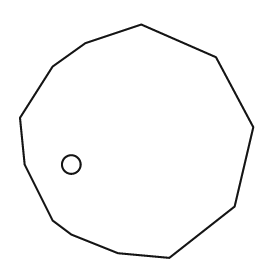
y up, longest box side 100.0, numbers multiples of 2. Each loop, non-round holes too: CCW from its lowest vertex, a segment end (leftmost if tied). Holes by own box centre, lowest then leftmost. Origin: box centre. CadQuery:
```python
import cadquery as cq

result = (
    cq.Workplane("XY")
    .moveTo(14.0, -50.0)
    .lineTo(42.0, -28.0)
    .lineTo(50.0, 6.0)
    .lineTo(34.0, 36.0)
    .lineTo(2.0, 50.0)
    .lineTo(-22.0, 42.0)
    .lineTo(-36.0, 32.0)
    .lineTo(-50.0, 10.0)
    .lineTo(-48.0, -10.0)
    .lineTo(-36.0, -34.0)
    .lineTo(-28.0, -40.0)
    .lineTo(-8.0, -48.0)
    .close()
    .moveTo(-28.0, -10.0)
    .circle(4.0)
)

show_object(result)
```